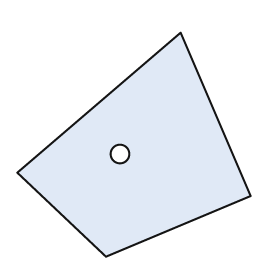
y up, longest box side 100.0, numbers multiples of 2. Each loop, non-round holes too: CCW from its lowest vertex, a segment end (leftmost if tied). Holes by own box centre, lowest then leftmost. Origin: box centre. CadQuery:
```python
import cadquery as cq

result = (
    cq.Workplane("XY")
    .moveTo(-12.0, -48.0)
    .lineTo(50.0, -22.0)
    .lineTo(20.0, 48.0)
    .lineTo(-50.0, -12.0)
    .close()
    .moveTo(-6.0, -4.0)
    .circle(4.0)
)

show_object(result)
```